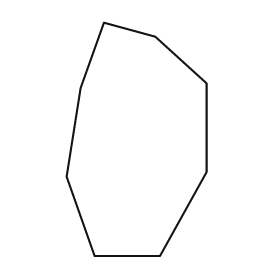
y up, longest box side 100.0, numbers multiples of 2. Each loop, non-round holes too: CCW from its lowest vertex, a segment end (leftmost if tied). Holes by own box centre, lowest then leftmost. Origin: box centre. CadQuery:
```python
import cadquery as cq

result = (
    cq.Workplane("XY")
    .moveTo(-18.0, -50.0)
    .lineTo(10.0, -50.0)
    .lineTo(30.0, -14.0)
    .lineTo(30.0, 24.0)
    .lineTo(8.0, 44.0)
    .lineTo(-14.0, 50.0)
    .lineTo(-24.0, 22.0)
    .lineTo(-30.0, -16.0)
    .close()
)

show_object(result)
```